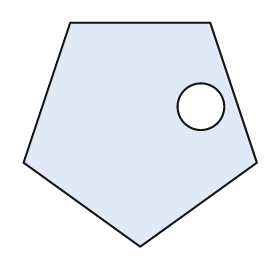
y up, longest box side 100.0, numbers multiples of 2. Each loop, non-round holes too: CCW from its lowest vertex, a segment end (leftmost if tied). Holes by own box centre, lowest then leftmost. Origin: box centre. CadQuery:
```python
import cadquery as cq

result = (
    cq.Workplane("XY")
    .moveTo(0.0, -48.0)
    .lineTo(50.0, -12.0)
    .lineTo(30.0, 48.0)
    .lineTo(-30.0, 48.0)
    .lineTo(-50.0, -12.0)
    .close()
    .moveTo(26.0, 12.0)
    .circle(10.0)
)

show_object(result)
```